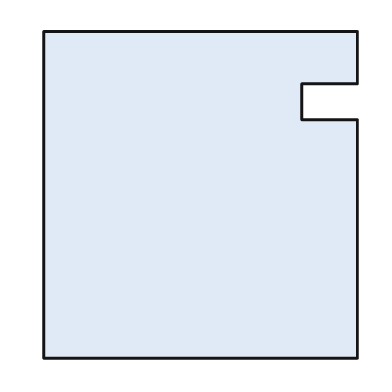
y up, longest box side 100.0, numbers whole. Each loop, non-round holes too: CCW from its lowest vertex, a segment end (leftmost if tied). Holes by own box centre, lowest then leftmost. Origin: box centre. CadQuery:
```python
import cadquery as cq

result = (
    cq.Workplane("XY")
    .moveTo(-48.0, -50.0)
    .lineTo(48.0, -50.0)
    .lineTo(48.0, 23.0)
    .lineTo(31.0, 23.0)
    .lineTo(31.0, 34.0)
    .lineTo(48.0, 34.0)
    .lineTo(48.0, 50.0)
    .lineTo(-48.0, 50.0)
    .close()
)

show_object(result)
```